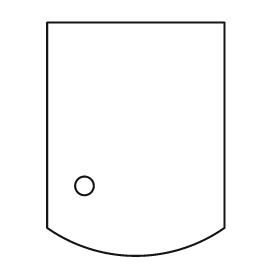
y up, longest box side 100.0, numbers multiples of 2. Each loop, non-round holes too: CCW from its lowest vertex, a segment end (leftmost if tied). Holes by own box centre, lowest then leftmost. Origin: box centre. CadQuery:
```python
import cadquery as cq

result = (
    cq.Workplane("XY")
    .moveTo(-38.0, -38.0)
    .threePointArc((0.0, -50.0), (38.0, -38.0))
    .lineTo(38.0, 50.0)
    .lineTo(-38.0, 50.0)
    .close()
    .moveTo(-22.0, -20.0)
    .circle(4.0)
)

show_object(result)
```